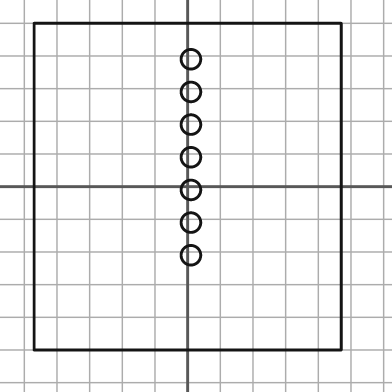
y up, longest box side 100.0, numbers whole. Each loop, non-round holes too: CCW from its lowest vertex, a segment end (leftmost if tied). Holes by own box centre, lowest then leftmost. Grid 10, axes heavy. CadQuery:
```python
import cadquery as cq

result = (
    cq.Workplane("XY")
    .moveTo(-47.0, -50.0)
    .lineTo(47.0, -50.0)
    .lineTo(47.0, 50.0)
    .lineTo(-47.0, 50.0)
    .close()
    .moveTo(1.0, -21.0)
    .circle(3.0)
    .moveTo(1.0, -11.0)
    .circle(3.0)
    .moveTo(1.0, -1.0)
    .circle(3.0)
    .moveTo(1.0, 9.0)
    .circle(3.0)
    .moveTo(1.0, 19.0)
    .circle(3.0)
    .moveTo(1.0, 29.0)
    .circle(3.0)
    .moveTo(1.0, 39.0)
    .circle(3.0)
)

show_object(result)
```